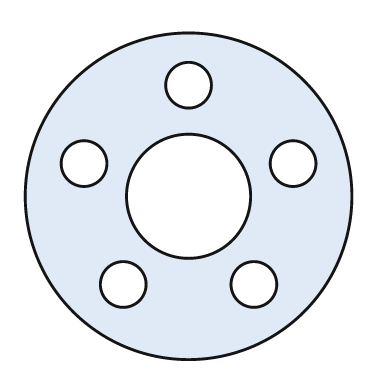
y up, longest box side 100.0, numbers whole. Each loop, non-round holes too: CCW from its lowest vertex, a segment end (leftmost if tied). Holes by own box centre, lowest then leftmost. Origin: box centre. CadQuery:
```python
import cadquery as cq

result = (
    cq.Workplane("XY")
    .moveTo(0.0, 0.0)
    .circle(50.0)
    .moveTo(-20.0, -27.0)
    .circle(7.0)
    .moveTo(20.0, -27.0)
    .circle(7.0)
    .moveTo(0.0, 0.0)
    .circle(19.0)
    .moveTo(-32.0, 10.0)
    .circle(7.0)
    .moveTo(32.0, 10.0)
    .circle(7.0)
    .moveTo(0.0, 34.0)
    .circle(7.0)
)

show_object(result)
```